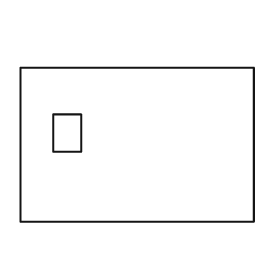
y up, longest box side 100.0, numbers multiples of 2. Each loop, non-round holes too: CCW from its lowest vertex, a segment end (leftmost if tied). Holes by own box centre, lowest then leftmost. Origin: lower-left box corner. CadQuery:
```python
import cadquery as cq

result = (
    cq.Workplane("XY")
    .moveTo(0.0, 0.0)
    .lineTo(100.0, 0.0)
    .lineTo(100.0, 66.0)
    .lineTo(0.0, 66.0)
    .close()
    .moveTo(14.0, 30.0)
    .lineTo(26.0, 30.0)
    .lineTo(26.0, 46.0)
    .lineTo(14.0, 46.0)
    .close()
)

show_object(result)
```